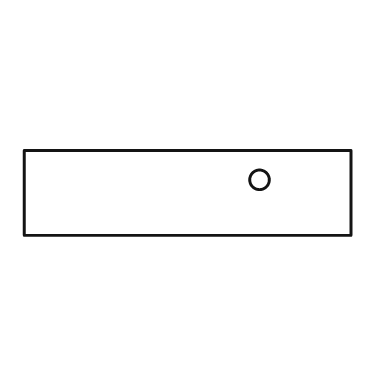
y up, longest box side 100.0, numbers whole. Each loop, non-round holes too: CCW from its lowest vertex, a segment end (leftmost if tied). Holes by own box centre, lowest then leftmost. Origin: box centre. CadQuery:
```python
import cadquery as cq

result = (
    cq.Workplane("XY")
    .moveTo(-50.0, -13.0)
    .lineTo(50.0, -13.0)
    .lineTo(50.0, 13.0)
    .lineTo(-50.0, 13.0)
    .close()
    .moveTo(22.0, 4.0)
    .circle(3.0)
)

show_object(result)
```